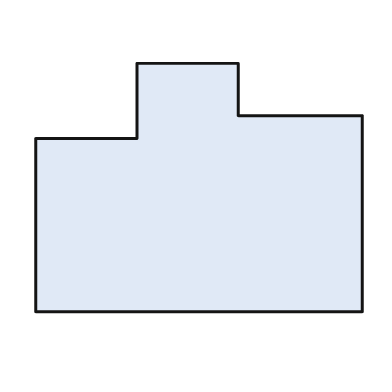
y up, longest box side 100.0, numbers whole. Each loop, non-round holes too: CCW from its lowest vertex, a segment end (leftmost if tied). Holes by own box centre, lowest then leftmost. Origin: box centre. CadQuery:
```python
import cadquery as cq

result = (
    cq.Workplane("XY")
    .moveTo(-50.0, -38.0)
    .lineTo(50.0, -38.0)
    .lineTo(50.0, 22.0)
    .lineTo(12.0, 22.0)
    .lineTo(12.0, 38.0)
    .lineTo(-19.0, 38.0)
    .lineTo(-19.0, 15.0)
    .lineTo(-50.0, 15.0)
    .close()
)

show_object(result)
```